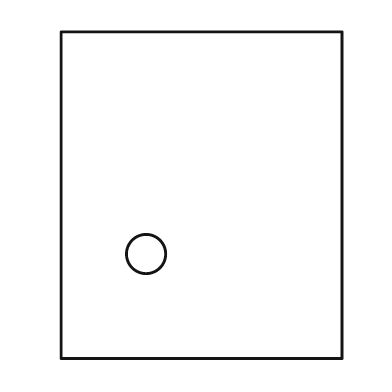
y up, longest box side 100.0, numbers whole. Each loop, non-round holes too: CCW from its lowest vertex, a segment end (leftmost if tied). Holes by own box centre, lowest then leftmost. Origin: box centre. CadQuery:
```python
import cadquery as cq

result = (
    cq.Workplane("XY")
    .moveTo(-43.0, -50.0)
    .lineTo(43.0, -50.0)
    .lineTo(43.0, 50.0)
    .lineTo(-43.0, 50.0)
    .close()
    .moveTo(-17.0, -18.0)
    .circle(6.0)
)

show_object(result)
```